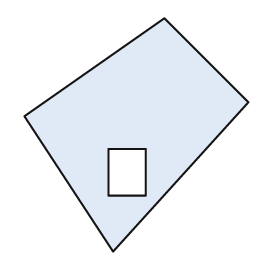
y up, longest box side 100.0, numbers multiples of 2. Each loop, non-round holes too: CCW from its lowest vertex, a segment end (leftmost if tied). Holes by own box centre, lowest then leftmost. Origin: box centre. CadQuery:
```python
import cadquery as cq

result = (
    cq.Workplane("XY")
    .moveTo(-10.0, -50.0)
    .lineTo(48.0, 14.0)
    .lineTo(12.0, 50.0)
    .lineTo(-48.0, 8.0)
    .close()
    .moveTo(-12.0, -26.0)
    .lineTo(4.0, -26.0)
    .lineTo(4.0, -6.0)
    .lineTo(-12.0, -6.0)
    .close()
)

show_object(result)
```